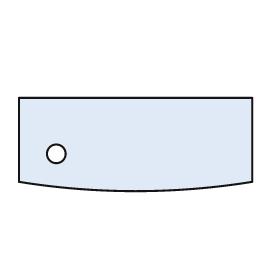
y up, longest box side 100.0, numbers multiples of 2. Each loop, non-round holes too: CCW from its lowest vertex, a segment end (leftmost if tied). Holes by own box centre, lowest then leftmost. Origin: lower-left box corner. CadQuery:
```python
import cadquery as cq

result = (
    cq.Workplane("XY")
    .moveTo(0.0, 4.0)
    .threePointArc((50.0, 0.0), (100.0, 4.0))
    .lineTo(100.0, 40.0)
    .lineTo(0.0, 40.0)
    .close()
    .moveTo(16.0, 16.0)
    .circle(4.0)
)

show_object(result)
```